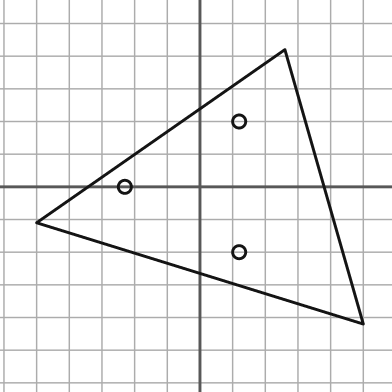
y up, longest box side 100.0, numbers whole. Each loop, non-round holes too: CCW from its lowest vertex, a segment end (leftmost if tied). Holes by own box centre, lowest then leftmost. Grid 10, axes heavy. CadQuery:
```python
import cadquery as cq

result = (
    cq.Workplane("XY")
    .moveTo(50.0, -42.0)
    .lineTo(26.0, 42.0)
    .lineTo(-50.0, -11.0)
    .close()
    .moveTo(12.0, -20.0)
    .circle(2.0)
    .moveTo(-23.0, 0.0)
    .circle(2.0)
    .moveTo(12.0, 20.0)
    .circle(2.0)
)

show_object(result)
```